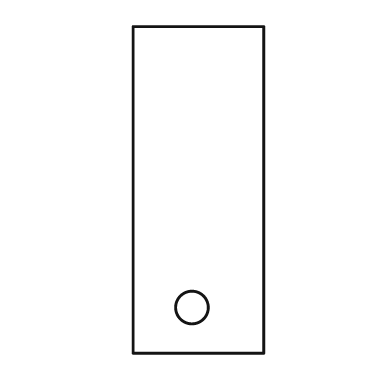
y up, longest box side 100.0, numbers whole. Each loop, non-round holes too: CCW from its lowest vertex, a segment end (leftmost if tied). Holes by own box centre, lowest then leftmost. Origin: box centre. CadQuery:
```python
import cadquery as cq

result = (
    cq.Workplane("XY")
    .moveTo(-20.0, -50.0)
    .lineTo(20.0, -50.0)
    .lineTo(20.0, 50.0)
    .lineTo(-20.0, 50.0)
    .close()
    .moveTo(-2.0, -36.0)
    .circle(5.0)
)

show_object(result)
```